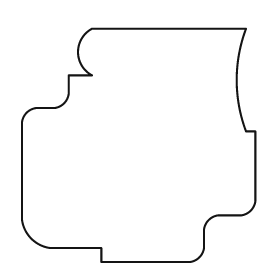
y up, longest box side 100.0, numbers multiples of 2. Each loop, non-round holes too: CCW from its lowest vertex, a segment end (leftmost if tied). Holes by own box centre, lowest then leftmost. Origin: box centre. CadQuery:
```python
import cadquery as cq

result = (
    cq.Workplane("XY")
    .moveTo(-16.0, -50.0)
    .lineTo(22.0, -50.0)
    .threePointArc((26.0, -48.0), (28.0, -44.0))
    .lineTo(28.0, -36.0)
    .threePointArc((30.0, -32.0), (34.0, -30.0))
    .lineTo(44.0, -30.0)
    .threePointArc((48.0, -28.0), (50.0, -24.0))
    .lineTo(50.0, 6.0)
    .lineTo(46.0, 6.0)
    .threePointArc((42.0, 28.0), (46.0, 50.0))
    .lineTo(-20.0, 50.0)
    .threePointArc((-26.0, 40.0), (-20.0, 30.0))
    .lineTo(-30.0, 30.0)
    .lineTo(-30.0, 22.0)
    .threePointArc((-32.0, 18.0), (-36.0, 16.0))
    .lineTo(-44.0, 16.0)
    .threePointArc((-48.0, 14.0), (-50.0, 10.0))
    .lineTo(-50.0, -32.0)
    .threePointArc((-46.0, -40.0), (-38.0, -44.0))
    .lineTo(-16.0, -44.0)
    .close()
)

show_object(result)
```